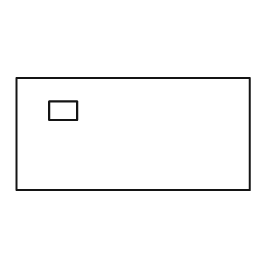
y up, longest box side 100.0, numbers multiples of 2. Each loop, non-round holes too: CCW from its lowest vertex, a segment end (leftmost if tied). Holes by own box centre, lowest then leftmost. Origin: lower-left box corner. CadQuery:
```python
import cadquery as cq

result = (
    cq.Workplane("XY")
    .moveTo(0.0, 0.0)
    .lineTo(100.0, 0.0)
    .lineTo(100.0, 48.0)
    .lineTo(0.0, 48.0)
    .close()
    .moveTo(14.0, 30.0)
    .lineTo(26.0, 30.0)
    .lineTo(26.0, 38.0)
    .lineTo(14.0, 38.0)
    .close()
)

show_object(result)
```